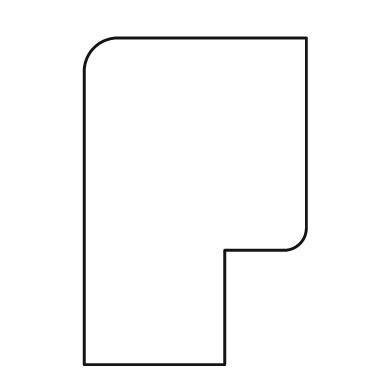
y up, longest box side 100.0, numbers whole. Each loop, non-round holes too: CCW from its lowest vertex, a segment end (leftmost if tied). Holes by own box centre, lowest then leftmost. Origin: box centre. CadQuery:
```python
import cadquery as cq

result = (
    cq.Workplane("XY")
    .moveTo(-34.0, -50.0)
    .lineTo(9.0, -50.0)
    .lineTo(9.0, -15.0)
    .lineTo(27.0, -15.0)
    .threePointArc((32.0, -13.0), (34.0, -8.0))
    .lineTo(34.0, 50.0)
    .lineTo(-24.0, 50.0)
    .threePointArc((-31.0, 47.0), (-34.0, 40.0))
    .close()
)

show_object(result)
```